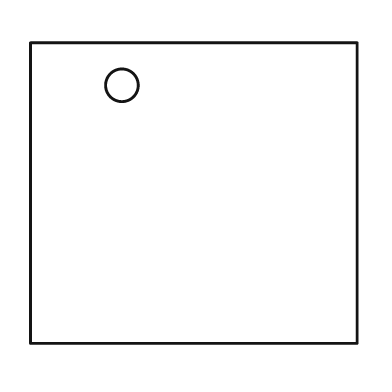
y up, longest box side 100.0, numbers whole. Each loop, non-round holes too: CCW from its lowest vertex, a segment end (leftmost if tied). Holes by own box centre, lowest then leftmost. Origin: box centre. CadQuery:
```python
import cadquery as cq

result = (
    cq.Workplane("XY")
    .moveTo(-50.0, -46.0)
    .lineTo(50.0, -46.0)
    .lineTo(50.0, 46.0)
    .lineTo(-50.0, 46.0)
    .close()
    .moveTo(-22.0, 33.0)
    .circle(5.0)
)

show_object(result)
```